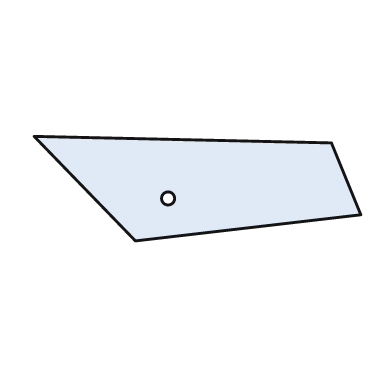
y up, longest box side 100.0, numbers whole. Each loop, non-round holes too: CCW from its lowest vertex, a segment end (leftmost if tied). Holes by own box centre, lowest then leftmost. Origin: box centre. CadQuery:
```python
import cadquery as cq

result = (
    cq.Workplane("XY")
    .moveTo(-19.0, -16.0)
    .lineTo(50.0, -8.0)
    .lineTo(41.0, 14.0)
    .lineTo(-50.0, 16.0)
    .close()
    .moveTo(-9.0, -3.0)
    .circle(2.0)
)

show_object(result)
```